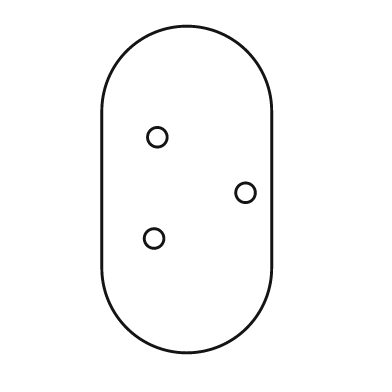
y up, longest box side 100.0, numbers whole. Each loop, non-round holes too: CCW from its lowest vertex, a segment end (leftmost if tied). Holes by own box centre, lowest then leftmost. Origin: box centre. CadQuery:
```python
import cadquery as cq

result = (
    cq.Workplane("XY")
    .moveTo(-26.0, -24.0)
    .threePointArc((0.0, -50.0), (26.0, -24.0))
    .lineTo(26.0, 24.0)
    .threePointArc((0.0, 50.0), (-26.0, 24.0))
    .close()
    .moveTo(-10.0, -15.0)
    .circle(3.0)
    .moveTo(18.0, -1.0)
    .circle(3.0)
    .moveTo(-9.0, 16.0)
    .circle(3.0)
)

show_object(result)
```